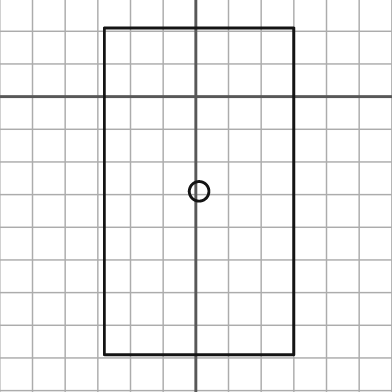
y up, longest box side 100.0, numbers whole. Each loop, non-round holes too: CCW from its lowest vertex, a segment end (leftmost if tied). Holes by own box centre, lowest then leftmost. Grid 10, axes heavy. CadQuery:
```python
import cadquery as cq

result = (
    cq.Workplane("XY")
    .moveTo(-28.0, -79.0)
    .lineTo(30.0, -79.0)
    .lineTo(30.0, 21.0)
    .lineTo(-28.0, 21.0)
    .close()
    .moveTo(1.0, -29.0)
    .circle(3.0)
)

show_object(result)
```